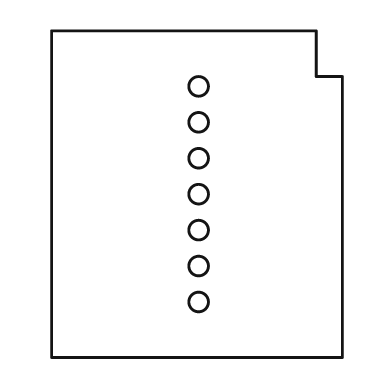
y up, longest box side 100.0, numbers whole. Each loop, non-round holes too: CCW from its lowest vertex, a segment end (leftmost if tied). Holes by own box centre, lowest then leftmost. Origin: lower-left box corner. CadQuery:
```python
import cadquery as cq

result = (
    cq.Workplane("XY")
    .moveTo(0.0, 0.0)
    .lineTo(89.0, 0.0)
    .lineTo(89.0, 86.0)
    .lineTo(81.0, 86.0)
    .lineTo(81.0, 100.0)
    .lineTo(0.0, 100.0)
    .close()
    .moveTo(45.0, 17.0)
    .circle(3.0)
    .moveTo(45.0, 28.0)
    .circle(3.0)
    .moveTo(45.0, 39.0)
    .circle(3.0)
    .moveTo(45.0, 50.0)
    .circle(3.0)
    .moveTo(45.0, 61.0)
    .circle(3.0)
    .moveTo(45.0, 72.0)
    .circle(3.0)
    .moveTo(45.0, 83.0)
    .circle(3.0)
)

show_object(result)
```